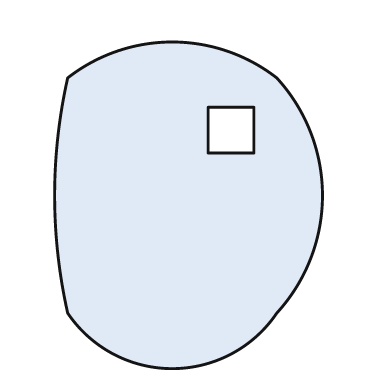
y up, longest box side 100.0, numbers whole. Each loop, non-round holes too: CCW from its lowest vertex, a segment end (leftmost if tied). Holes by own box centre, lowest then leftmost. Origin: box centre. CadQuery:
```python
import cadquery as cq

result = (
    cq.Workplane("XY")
    .moveTo(-37.0, -33.0)
    .threePointArc((-5.0, -50.0), (27.0, -33.0))
    .threePointArc((41.0, 3.0), (27.0, 39.0))
    .threePointArc((-5.0, 50.0), (-37.0, 39.0))
    .threePointArc((-41.0, 3.0), (-37.0, -33.0))
    .close()
    .moveTo(6.0, 16.0)
    .lineTo(20.0, 16.0)
    .lineTo(20.0, 30.0)
    .lineTo(6.0, 30.0)
    .close()
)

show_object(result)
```